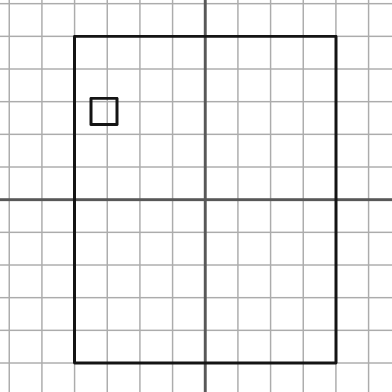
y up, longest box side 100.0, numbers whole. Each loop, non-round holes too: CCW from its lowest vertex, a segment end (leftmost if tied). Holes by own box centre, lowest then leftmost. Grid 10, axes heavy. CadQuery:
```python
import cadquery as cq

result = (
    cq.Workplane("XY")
    .moveTo(-40.0, -50.0)
    .lineTo(40.0, -50.0)
    .lineTo(40.0, 50.0)
    .lineTo(-40.0, 50.0)
    .close()
    .moveTo(-35.0, 23.0)
    .lineTo(-27.0, 23.0)
    .lineTo(-27.0, 31.0)
    .lineTo(-35.0, 31.0)
    .close()
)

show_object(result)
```